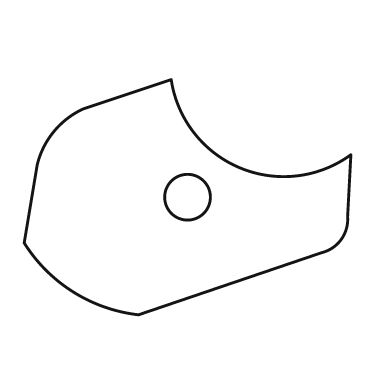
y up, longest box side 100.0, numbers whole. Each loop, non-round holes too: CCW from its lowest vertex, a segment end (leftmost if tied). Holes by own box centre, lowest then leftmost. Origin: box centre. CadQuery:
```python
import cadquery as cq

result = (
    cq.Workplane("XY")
    .moveTo(-15.0, -36.0)
    .lineTo(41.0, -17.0)
    .threePointArc((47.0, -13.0), (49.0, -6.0))
    .lineTo(50.0, 13.0)
    .threePointArc((16.0, 9.0), (-5.0, 36.0))
    .lineTo(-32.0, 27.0)
    .threePointArc((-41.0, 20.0), (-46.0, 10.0))
    .lineTo(-50.0, -14.0)
    .threePointArc((-35.0, -29.0), (-15.0, -36.0))
    .close()
    .moveTo(0.0, 0.0)
    .circle(7.0)
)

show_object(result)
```